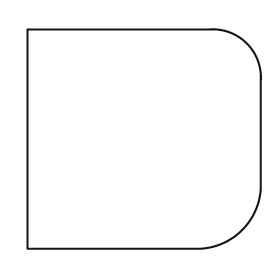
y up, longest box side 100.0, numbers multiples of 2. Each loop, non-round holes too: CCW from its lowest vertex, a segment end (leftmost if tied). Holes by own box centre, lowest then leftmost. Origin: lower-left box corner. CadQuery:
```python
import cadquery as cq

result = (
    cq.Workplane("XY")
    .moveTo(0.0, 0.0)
    .lineTo(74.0, 0.0)
    .threePointArc((92.0, 8.0), (100.0, 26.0))
    .lineTo(100.0, 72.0)
    .threePointArc((94.0, 88.0), (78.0, 94.0))
    .lineTo(0.0, 94.0)
    .close()
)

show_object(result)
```